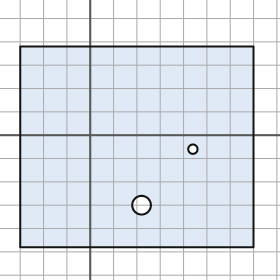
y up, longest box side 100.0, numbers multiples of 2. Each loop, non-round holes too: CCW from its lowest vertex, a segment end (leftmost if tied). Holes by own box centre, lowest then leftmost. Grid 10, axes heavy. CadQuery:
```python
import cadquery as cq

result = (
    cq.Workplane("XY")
    .moveTo(-30.0, -48.0)
    .lineTo(70.0, -48.0)
    .lineTo(70.0, 38.0)
    .lineTo(-30.0, 38.0)
    .close()
    .moveTo(22.0, -30.0)
    .circle(4.0)
    .moveTo(44.0, -6.0)
    .circle(2.0)
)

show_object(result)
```